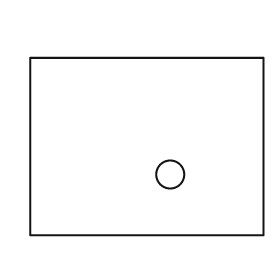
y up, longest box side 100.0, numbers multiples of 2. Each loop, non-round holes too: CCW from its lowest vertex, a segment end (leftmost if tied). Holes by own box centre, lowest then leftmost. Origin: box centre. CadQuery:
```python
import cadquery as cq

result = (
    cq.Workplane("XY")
    .moveTo(-50.0, -38.0)
    .lineTo(50.0, -38.0)
    .lineTo(50.0, 38.0)
    .lineTo(-50.0, 38.0)
    .close()
    .moveTo(10.0, -12.0)
    .circle(6.0)
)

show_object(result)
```